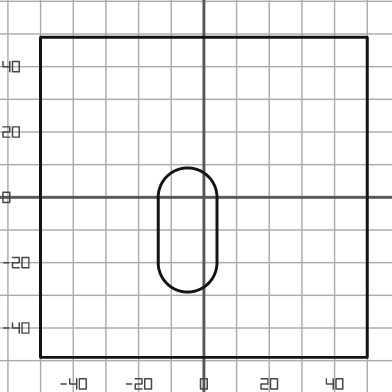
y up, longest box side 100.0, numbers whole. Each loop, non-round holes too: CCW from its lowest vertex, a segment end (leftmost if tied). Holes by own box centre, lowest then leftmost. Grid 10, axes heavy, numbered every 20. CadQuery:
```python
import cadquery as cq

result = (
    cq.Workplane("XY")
    .moveTo(-50.0, -49.0)
    .lineTo(50.0, -49.0)
    .lineTo(50.0, 49.0)
    .lineTo(-50.0, 49.0)
    .close()
    .moveTo(-14.0, -20.0)
    .threePointArc((-5.0, -29.0), (4.0, -20.0))
    .lineTo(4.0, 0.0)
    .threePointArc((-5.0, 9.0), (-14.0, 0.0))
    .close()
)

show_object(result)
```